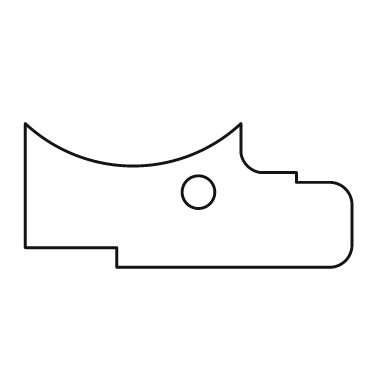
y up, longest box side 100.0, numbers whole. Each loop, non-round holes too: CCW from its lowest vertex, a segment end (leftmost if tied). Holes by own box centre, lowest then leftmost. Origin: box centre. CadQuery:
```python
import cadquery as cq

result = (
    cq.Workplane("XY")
    .moveTo(-22.0, -22.0)
    .lineTo(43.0, -22.0)
    .threePointArc((48.0, -20.0), (50.0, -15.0))
    .lineTo(50.0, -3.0)
    .threePointArc((48.0, 2.0), (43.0, 4.0))
    .lineTo(33.0, 4.0)
    .lineTo(33.0, 7.0)
    .lineTo(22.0, 7.0)
    .threePointArc((18.0, 9.0), (16.0, 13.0))
    .lineTo(16.0, 22.0)
    .threePointArc((-17.0, 9.0), (-50.0, 22.0))
    .lineTo(-50.0, -16.0)
    .lineTo(-22.0, -16.0)
    .close()
    .moveTo(3.0, 1.0)
    .circle(5.0)
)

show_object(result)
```